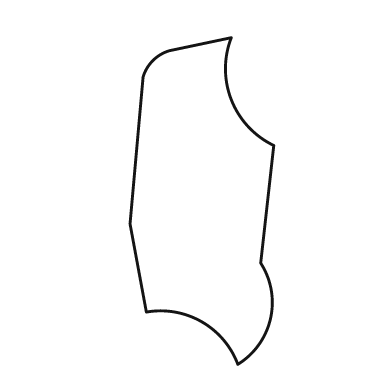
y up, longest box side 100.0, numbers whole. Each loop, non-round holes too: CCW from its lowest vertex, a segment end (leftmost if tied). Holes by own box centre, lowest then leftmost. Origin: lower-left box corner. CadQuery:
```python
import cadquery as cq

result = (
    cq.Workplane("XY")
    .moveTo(33.0, 0.0)
    .threePointArc((43.0, 14.0), (40.0, 31.0))
    .lineTo(44.0, 67.0)
    .threePointArc((31.0, 81.0), (31.0, 100.0))
    .lineTo(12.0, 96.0)
    .threePointArc((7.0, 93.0), (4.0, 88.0))
    .lineTo(0.0, 43.0)
    .lineTo(5.0, 16.0)
    .threePointArc((22.0, 13.0), (33.0, 0.0))
    .close()
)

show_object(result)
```